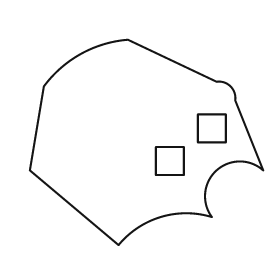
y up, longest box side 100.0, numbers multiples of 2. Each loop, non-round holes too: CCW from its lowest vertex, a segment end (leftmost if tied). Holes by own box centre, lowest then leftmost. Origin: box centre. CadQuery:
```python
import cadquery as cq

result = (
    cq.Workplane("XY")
    .moveTo(-12.0, -44.0)
    .threePointArc((6.0, -32.0), (28.0, -32.0))
    .threePointArc((30.0, -12.0), (50.0, -12.0))
    .lineTo(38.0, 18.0)
    .threePointArc((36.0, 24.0), (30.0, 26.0))
    .lineTo(-8.0, 44.0)
    .threePointArc((-28.0, 38.0), (-44.0, 24.0))
    .lineTo(-50.0, -12.0)
    .close()
    .moveTo(4.0, -14.0)
    .lineTo(16.0, -14.0)
    .lineTo(16.0, -2.0)
    .lineTo(4.0, -2.0)
    .close()
    .moveTo(22.0, 0.0)
    .lineTo(34.0, 0.0)
    .lineTo(34.0, 12.0)
    .lineTo(22.0, 12.0)
    .close()
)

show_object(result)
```